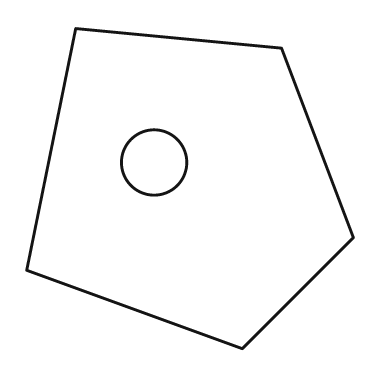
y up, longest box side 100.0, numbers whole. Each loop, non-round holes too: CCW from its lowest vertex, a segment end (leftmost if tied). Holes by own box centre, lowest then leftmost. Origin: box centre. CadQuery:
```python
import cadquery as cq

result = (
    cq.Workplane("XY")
    .moveTo(16.0, -49.0)
    .lineTo(50.0, -15.0)
    .lineTo(28.0, 43.0)
    .lineTo(-35.0, 49.0)
    .lineTo(-50.0, -25.0)
    .close()
    .moveTo(-11.0, 8.0)
    .circle(10.0)
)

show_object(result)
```